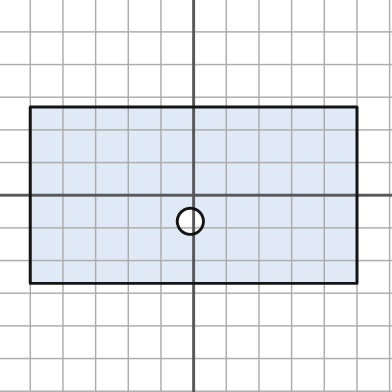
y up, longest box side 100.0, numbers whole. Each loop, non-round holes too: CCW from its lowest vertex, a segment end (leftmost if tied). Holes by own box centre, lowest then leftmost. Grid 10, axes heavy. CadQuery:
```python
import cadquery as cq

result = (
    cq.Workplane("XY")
    .moveTo(-50.0, -27.0)
    .lineTo(50.0, -27.0)
    .lineTo(50.0, 27.0)
    .lineTo(-50.0, 27.0)
    .close()
    .moveTo(-1.0, -8.0)
    .circle(4.0)
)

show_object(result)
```